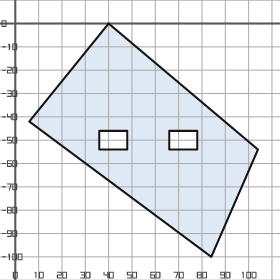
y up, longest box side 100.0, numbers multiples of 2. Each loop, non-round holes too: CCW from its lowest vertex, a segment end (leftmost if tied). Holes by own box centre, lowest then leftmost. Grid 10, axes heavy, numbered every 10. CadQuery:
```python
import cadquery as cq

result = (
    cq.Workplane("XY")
    .moveTo(84.0, -100.0)
    .lineTo(104.0, -54.0)
    .lineTo(40.0, 0.0)
    .lineTo(6.0, -42.0)
    .close()
    .moveTo(36.0, -54.0)
    .lineTo(48.0, -54.0)
    .lineTo(48.0, -46.0)
    .lineTo(36.0, -46.0)
    .close()
    .moveTo(66.0, -54.0)
    .lineTo(78.0, -54.0)
    .lineTo(78.0, -46.0)
    .lineTo(66.0, -46.0)
    .close()
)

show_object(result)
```